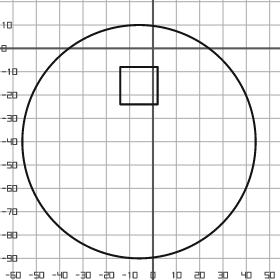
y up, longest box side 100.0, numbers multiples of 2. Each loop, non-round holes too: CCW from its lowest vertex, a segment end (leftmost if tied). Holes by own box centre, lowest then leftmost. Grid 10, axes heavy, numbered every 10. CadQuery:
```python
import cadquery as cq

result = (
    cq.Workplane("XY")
    .moveTo(-6.0, -40.0)
    .circle(50.0)
    .moveTo(-14.0, -24.0)
    .lineTo(2.0, -24.0)
    .lineTo(2.0, -8.0)
    .lineTo(-14.0, -8.0)
    .close()
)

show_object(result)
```